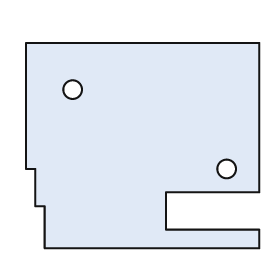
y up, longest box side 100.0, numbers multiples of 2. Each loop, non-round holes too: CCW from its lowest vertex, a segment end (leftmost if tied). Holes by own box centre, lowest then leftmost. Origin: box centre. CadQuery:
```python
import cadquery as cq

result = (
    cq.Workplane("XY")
    .moveTo(-42.0, -44.0)
    .lineTo(50.0, -44.0)
    .lineTo(50.0, -36.0)
    .lineTo(10.0, -36.0)
    .lineTo(10.0, -20.0)
    .lineTo(50.0, -20.0)
    .lineTo(50.0, 44.0)
    .lineTo(-50.0, 44.0)
    .lineTo(-50.0, -10.0)
    .lineTo(-46.0, -10.0)
    .lineTo(-46.0, -26.0)
    .lineTo(-42.0, -26.0)
    .close()
    .moveTo(36.0, -10.0)
    .circle(4.0)
    .moveTo(-30.0, 24.0)
    .circle(4.0)
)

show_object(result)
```